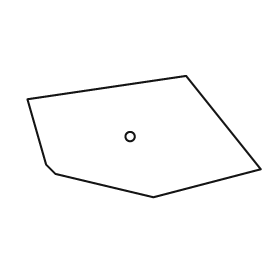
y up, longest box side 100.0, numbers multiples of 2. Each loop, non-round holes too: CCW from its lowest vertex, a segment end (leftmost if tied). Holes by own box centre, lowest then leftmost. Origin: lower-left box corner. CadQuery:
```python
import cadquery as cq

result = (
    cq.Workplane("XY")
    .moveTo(54.0, 0.0)
    .lineTo(100.0, 12.0)
    .lineTo(68.0, 52.0)
    .lineTo(0.0, 42.0)
    .lineTo(8.0, 14.0)
    .lineTo(12.0, 10.0)
    .close()
    .moveTo(44.0, 26.0)
    .circle(2.0)
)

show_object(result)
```